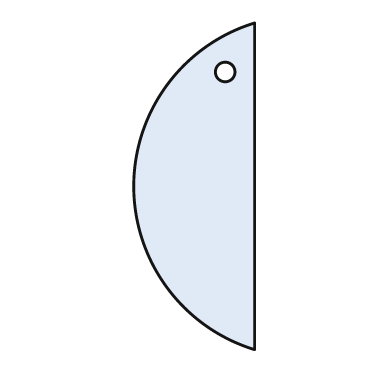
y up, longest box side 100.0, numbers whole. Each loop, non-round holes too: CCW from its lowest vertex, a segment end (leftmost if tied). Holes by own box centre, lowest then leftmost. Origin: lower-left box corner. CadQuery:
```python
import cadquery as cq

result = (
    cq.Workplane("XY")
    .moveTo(37.0, 0.0)
    .lineTo(37.0, 100.0)
    .threePointArc((0.0, 50.0), (37.0, 0.0))
    .close()
    .moveTo(28.0, 85.0)
    .circle(3.0)
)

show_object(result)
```